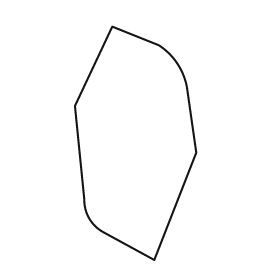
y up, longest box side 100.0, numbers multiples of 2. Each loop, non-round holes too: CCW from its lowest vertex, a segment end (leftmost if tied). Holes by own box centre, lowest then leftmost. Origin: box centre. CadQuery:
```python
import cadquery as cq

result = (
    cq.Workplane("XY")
    .moveTo(8.0, -50.0)
    .lineTo(26.0, -4.0)
    .lineTo(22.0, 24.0)
    .threePointArc((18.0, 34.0), (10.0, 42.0))
    .lineTo(-10.0, 50.0)
    .lineTo(-26.0, 16.0)
    .lineTo(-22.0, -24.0)
    .threePointArc((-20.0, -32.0), (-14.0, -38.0))
    .close()
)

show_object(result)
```